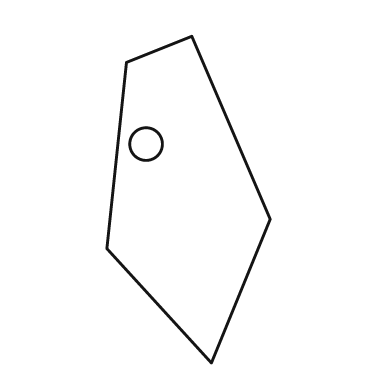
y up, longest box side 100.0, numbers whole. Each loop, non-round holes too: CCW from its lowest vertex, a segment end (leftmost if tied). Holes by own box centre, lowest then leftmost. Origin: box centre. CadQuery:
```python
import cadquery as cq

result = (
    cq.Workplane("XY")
    .moveTo(7.0, -50.0)
    .lineTo(25.0, -6.0)
    .lineTo(1.0, 50.0)
    .lineTo(-19.0, 42.0)
    .lineTo(-25.0, -15.0)
    .close()
    .moveTo(-13.0, 17.0)
    .circle(5.0)
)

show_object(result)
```